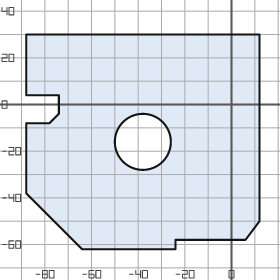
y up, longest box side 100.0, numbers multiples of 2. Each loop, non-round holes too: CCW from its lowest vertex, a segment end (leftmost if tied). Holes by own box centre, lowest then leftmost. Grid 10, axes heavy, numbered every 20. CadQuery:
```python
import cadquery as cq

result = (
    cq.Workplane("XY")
    .moveTo(-64.0, -62.0)
    .lineTo(-24.0, -62.0)
    .lineTo(-24.0, -58.0)
    .lineTo(6.0, -58.0)
    .lineTo(12.0, -50.0)
    .lineTo(12.0, 30.0)
    .lineTo(-88.0, 30.0)
    .lineTo(-88.0, 4.0)
    .lineTo(-74.0, 4.0)
    .lineTo(-74.0, -4.0)
    .lineTo(-78.0, -8.0)
    .lineTo(-88.0, -8.0)
    .lineTo(-88.0, -38.0)
    .close()
    .moveTo(-38.0, -16.0)
    .circle(12.0)
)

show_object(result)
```